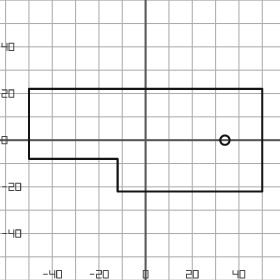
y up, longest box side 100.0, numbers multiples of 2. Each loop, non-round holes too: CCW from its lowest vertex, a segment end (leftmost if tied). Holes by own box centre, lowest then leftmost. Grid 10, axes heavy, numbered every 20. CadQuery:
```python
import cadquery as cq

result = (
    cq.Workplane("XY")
    .moveTo(-12.0, -22.0)
    .lineTo(50.0, -22.0)
    .lineTo(50.0, 22.0)
    .lineTo(-50.0, 22.0)
    .lineTo(-50.0, -8.0)
    .lineTo(-12.0, -8.0)
    .close()
    .moveTo(34.0, 0.0)
    .circle(2.0)
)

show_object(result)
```